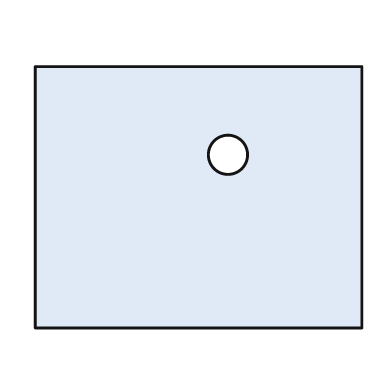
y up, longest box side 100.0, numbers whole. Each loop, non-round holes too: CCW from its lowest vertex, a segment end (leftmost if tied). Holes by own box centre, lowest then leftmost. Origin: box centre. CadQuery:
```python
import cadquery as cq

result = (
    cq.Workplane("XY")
    .moveTo(-50.0, -40.0)
    .lineTo(50.0, -40.0)
    .lineTo(50.0, 40.0)
    .lineTo(-50.0, 40.0)
    .close()
    .moveTo(9.0, 13.0)
    .circle(6.0)
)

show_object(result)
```